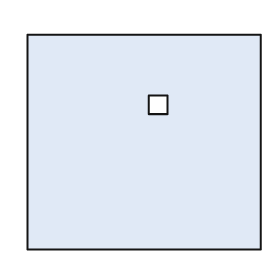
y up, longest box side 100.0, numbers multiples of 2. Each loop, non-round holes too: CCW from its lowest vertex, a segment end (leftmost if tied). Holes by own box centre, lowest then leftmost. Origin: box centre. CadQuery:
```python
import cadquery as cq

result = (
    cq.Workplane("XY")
    .moveTo(-50.0, -46.0)
    .lineTo(50.0, -46.0)
    .lineTo(50.0, 46.0)
    .lineTo(-50.0, 46.0)
    .close()
    .moveTo(2.0, 12.0)
    .lineTo(10.0, 12.0)
    .lineTo(10.0, 20.0)
    .lineTo(2.0, 20.0)
    .close()
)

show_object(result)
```